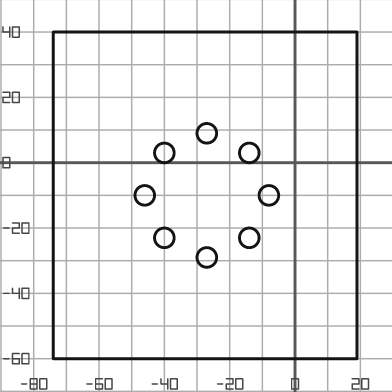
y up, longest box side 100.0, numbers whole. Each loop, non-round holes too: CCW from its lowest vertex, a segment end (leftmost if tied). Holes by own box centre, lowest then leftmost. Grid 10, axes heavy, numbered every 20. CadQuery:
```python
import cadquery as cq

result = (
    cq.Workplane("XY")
    .moveTo(-74.0, -60.0)
    .lineTo(19.0, -60.0)
    .lineTo(19.0, 40.0)
    .lineTo(-74.0, 40.0)
    .close()
    .moveTo(-27.0, -29.0)
    .circle(3.0)
    .moveTo(-40.0, -23.0)
    .circle(3.0)
    .moveTo(-14.0, -23.0)
    .circle(3.0)
    .moveTo(-46.0, -10.0)
    .circle(3.0)
    .moveTo(-8.0, -10.0)
    .circle(3.0)
    .moveTo(-40.0, 3.0)
    .circle(3.0)
    .moveTo(-14.0, 3.0)
    .circle(3.0)
    .moveTo(-27.0, 9.0)
    .circle(3.0)
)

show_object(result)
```